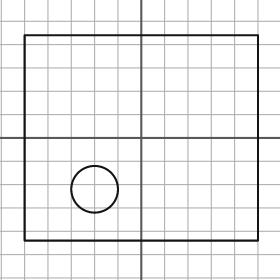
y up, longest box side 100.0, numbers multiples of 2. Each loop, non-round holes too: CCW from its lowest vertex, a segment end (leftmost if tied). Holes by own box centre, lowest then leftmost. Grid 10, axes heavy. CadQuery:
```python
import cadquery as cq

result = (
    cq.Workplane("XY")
    .moveTo(-50.0, -44.0)
    .lineTo(50.0, -44.0)
    .lineTo(50.0, 44.0)
    .lineTo(-50.0, 44.0)
    .close()
    .moveTo(-20.0, -22.0)
    .circle(10.0)
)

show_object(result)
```